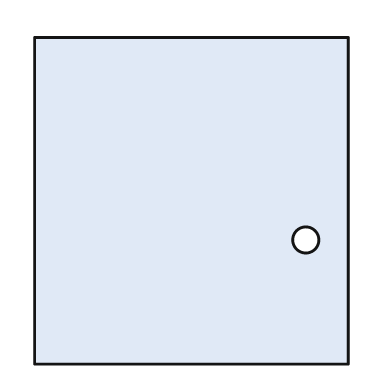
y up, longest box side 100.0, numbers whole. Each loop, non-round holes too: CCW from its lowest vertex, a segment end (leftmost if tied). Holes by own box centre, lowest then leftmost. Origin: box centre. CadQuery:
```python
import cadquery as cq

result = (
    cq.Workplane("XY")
    .moveTo(-48.0, -50.0)
    .lineTo(48.0, -50.0)
    .lineTo(48.0, 50.0)
    .lineTo(-48.0, 50.0)
    .close()
    .moveTo(35.0, -12.0)
    .circle(4.0)
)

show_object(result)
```